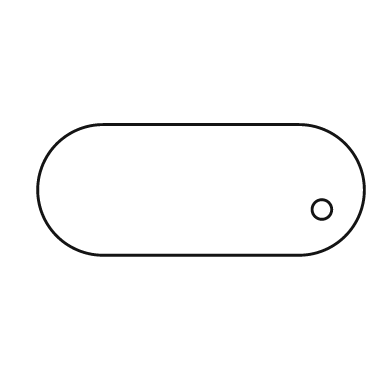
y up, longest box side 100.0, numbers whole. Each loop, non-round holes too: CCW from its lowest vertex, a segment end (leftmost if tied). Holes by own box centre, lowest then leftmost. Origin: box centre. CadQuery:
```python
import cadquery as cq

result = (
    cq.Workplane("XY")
    .moveTo(-30.0, -20.0)
    .lineTo(30.0, -20.0)
    .threePointArc((50.0, 0.0), (30.0, 20.0))
    .lineTo(-30.0, 20.0)
    .threePointArc((-50.0, 0.0), (-30.0, -20.0))
    .close()
    .moveTo(37.0, -6.0)
    .circle(3.0)
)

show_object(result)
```